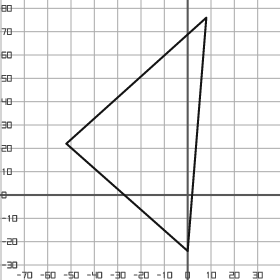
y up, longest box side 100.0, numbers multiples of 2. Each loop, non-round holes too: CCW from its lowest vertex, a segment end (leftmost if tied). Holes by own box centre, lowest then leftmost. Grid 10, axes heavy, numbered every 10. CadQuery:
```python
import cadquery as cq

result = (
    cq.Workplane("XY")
    .moveTo(0.0, -24.0)
    .lineTo(8.0, 76.0)
    .lineTo(-52.0, 22.0)
    .close()
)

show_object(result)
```